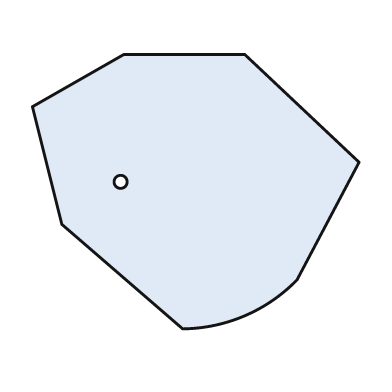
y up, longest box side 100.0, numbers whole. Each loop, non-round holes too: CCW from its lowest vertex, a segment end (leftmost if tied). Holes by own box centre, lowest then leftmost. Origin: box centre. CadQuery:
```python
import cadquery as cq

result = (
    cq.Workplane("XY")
    .moveTo(-4.0, -42.0)
    .threePointArc((15.0, -38.0), (31.0, -27.0))
    .lineTo(50.0, 9.0)
    .lineTo(15.0, 42.0)
    .lineTo(-22.0, 42.0)
    .lineTo(-50.0, 26.0)
    .lineTo(-41.0, -10.0)
    .close()
    .moveTo(-23.0, 3.0)
    .circle(2.0)
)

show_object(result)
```